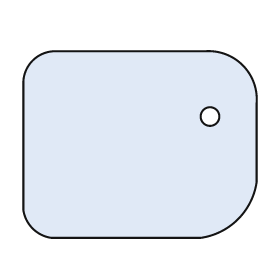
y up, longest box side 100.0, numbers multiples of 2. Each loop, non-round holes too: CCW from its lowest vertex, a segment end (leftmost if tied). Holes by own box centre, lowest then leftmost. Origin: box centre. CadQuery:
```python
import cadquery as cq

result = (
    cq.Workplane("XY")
    .moveTo(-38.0, -40.0)
    .lineTo(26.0, -40.0)
    .threePointArc((42.0, -32.0), (50.0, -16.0))
    .lineTo(50.0, 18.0)
    .threePointArc((44.0, 34.0), (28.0, 40.0))
    .lineTo(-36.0, 40.0)
    .threePointArc((-46.0, 36.0), (-50.0, 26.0))
    .lineTo(-50.0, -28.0)
    .threePointArc((-46.0, -36.0), (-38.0, -40.0))
    .close()
    .moveTo(30.0, 12.0)
    .circle(4.0)
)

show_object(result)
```